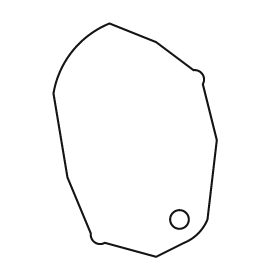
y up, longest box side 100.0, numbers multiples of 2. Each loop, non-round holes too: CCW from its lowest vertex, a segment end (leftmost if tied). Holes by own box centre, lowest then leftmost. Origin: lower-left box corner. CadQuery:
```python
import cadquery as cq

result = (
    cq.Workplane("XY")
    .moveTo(44.0, 0.0)
    .lineTo(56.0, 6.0)
    .threePointArc((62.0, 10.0), (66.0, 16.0))
    .lineTo(70.0, 50.0)
    .lineTo(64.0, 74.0)
    .threePointArc((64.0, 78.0), (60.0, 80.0))
    .lineTo(44.0, 92.0)
    .lineTo(24.0, 100.0)
    .threePointArc((8.0, 88.0), (0.0, 70.0))
    .lineTo(6.0, 34.0)
    .lineTo(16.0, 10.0)
    .threePointArc((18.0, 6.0), (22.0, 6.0))
    .close()
    .moveTo(54.0, 16.0)
    .circle(4.0)
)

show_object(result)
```